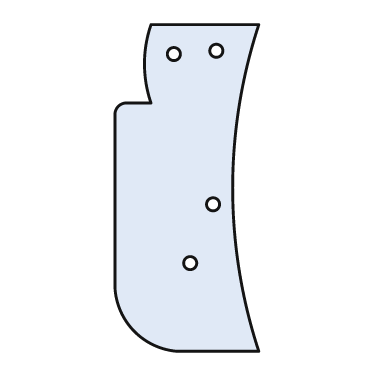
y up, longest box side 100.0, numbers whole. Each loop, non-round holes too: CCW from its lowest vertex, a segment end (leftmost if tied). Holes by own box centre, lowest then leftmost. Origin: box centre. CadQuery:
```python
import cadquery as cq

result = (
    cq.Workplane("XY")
    .moveTo(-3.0, -50.0)
    .lineTo(22.0, -50.0)
    .threePointArc((14.0, 0.0), (22.0, 50.0))
    .lineTo(-11.0, 50.0)
    .threePointArc((-13.0, 38.0), (-11.0, 26.0))
    .lineTo(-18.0, 26.0)
    .threePointArc((-21.0, 25.0), (-22.0, 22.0))
    .lineTo(-22.0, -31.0)
    .threePointArc((-16.0, -44.0), (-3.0, -50.0))
    .close()
    .moveTo(1.0, -23.0)
    .circle(2.0)
    .moveTo(8.0, -5.0)
    .circle(2.0)
    .moveTo(-4.0, 41.0)
    .circle(2.0)
    .moveTo(9.0, 42.0)
    .circle(2.0)
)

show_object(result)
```